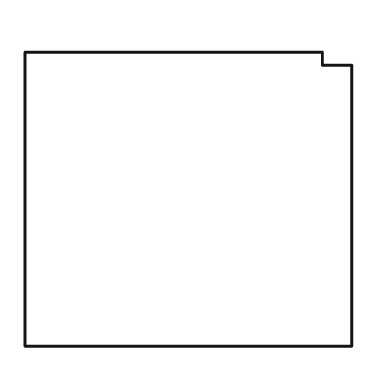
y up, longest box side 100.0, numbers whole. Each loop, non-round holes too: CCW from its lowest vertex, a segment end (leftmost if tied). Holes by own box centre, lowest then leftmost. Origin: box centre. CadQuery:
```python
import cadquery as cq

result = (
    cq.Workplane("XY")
    .moveTo(-50.0, -45.0)
    .lineTo(50.0, -45.0)
    .lineTo(50.0, 41.0)
    .lineTo(41.0, 41.0)
    .lineTo(41.0, 45.0)
    .lineTo(-50.0, 45.0)
    .close()
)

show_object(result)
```